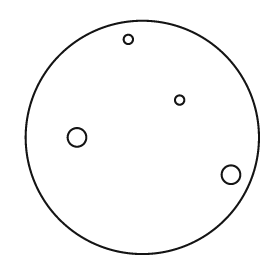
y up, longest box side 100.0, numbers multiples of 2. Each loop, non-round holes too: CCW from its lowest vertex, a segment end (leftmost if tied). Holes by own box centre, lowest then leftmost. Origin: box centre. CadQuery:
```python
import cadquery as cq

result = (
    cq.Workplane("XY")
    .moveTo(0.0, 0.0)
    .circle(50.0)
    .moveTo(38.0, -16.0)
    .circle(4.0)
    .moveTo(-28.0, 0.0)
    .circle(4.0)
    .moveTo(16.0, 16.0)
    .circle(2.0)
    .moveTo(-6.0, 42.0)
    .circle(2.0)
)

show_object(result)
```